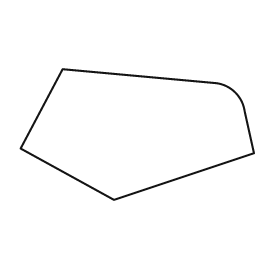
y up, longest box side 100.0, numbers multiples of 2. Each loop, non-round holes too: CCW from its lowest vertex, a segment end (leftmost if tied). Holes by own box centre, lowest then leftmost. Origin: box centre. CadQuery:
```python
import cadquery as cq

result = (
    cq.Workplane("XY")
    .moveTo(-10.0, -28.0)
    .lineTo(50.0, -8.0)
    .lineTo(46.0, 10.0)
    .threePointArc((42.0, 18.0), (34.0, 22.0))
    .lineTo(-32.0, 28.0)
    .lineTo(-50.0, -6.0)
    .close()
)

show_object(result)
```